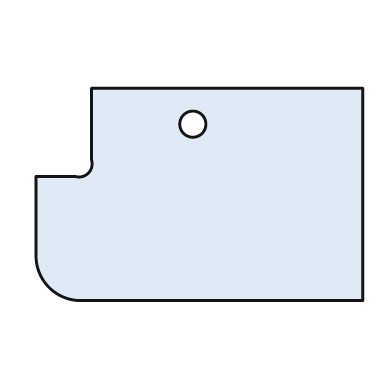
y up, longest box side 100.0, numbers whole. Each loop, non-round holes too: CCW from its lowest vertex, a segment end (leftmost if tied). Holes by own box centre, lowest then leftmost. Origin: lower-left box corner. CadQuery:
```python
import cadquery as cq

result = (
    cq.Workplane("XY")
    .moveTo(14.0, 0.0)
    .lineTo(100.0, 0.0)
    .lineTo(100.0, 65.0)
    .lineTo(17.0, 65.0)
    .lineTo(17.0, 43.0)
    .threePointArc((16.0, 39.0), (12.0, 38.0))
    .lineTo(0.0, 38.0)
    .lineTo(0.0, 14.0)
    .threePointArc((4.0, 4.0), (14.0, 0.0))
    .close()
    .moveTo(48.0, 54.0)
    .circle(4.0)
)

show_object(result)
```